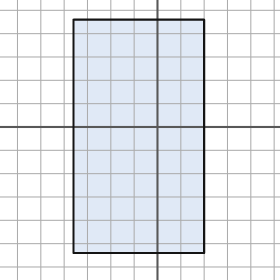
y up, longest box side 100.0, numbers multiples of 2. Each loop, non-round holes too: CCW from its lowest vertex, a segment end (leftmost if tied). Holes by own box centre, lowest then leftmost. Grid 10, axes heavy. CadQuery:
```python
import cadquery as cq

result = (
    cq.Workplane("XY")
    .moveTo(-36.0, -54.0)
    .lineTo(20.0, -54.0)
    .lineTo(20.0, 46.0)
    .lineTo(-36.0, 46.0)
    .close()
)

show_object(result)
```